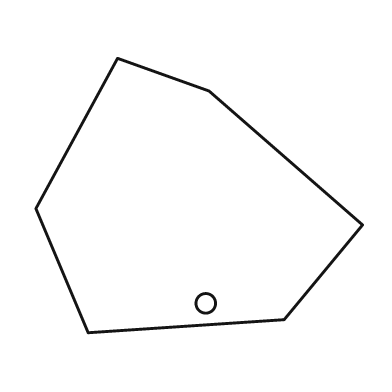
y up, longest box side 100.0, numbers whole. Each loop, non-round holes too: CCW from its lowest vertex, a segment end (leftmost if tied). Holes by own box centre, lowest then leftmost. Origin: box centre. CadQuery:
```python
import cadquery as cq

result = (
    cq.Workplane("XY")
    .moveTo(-34.0, -42.0)
    .lineTo(26.0, -38.0)
    .lineTo(50.0, -9.0)
    .lineTo(3.0, 32.0)
    .lineTo(-25.0, 42.0)
    .lineTo(-50.0, -4.0)
    .close()
    .moveTo(2.0, -33.0)
    .circle(3.0)
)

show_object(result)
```